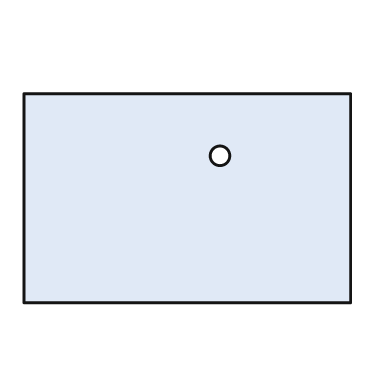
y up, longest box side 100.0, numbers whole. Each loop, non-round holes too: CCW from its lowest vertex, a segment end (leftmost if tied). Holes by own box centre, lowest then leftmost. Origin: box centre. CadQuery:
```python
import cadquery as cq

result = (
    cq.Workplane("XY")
    .moveTo(-50.0, -32.0)
    .lineTo(50.0, -32.0)
    .lineTo(50.0, 32.0)
    .lineTo(-50.0, 32.0)
    .close()
    .moveTo(10.0, 13.0)
    .circle(3.0)
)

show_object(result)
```